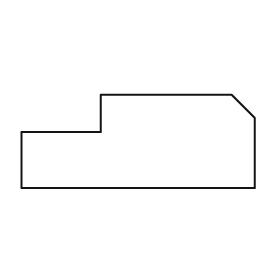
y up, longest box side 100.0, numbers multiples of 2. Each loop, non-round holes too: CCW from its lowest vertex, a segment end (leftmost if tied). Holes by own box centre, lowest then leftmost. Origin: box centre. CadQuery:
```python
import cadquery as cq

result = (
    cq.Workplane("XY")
    .moveTo(-50.0, -20.0)
    .lineTo(50.0, -20.0)
    .lineTo(50.0, 10.0)
    .lineTo(40.0, 20.0)
    .lineTo(-16.0, 20.0)
    .lineTo(-16.0, 4.0)
    .lineTo(-50.0, 4.0)
    .close()
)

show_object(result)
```